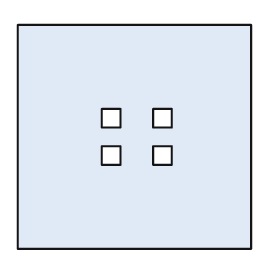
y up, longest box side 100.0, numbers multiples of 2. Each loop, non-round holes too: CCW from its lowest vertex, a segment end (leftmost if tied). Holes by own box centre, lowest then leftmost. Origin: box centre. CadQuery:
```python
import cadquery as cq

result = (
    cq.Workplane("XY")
    .moveTo(-50.0, -48.0)
    .lineTo(50.0, -48.0)
    .lineTo(50.0, 48.0)
    .lineTo(-50.0, 48.0)
    .close()
    .moveTo(-14.0, -12.0)
    .lineTo(-6.0, -12.0)
    .lineTo(-6.0, -4.0)
    .lineTo(-14.0, -4.0)
    .close()
    .moveTo(8.0, -12.0)
    .lineTo(16.0, -12.0)
    .lineTo(16.0, -4.0)
    .lineTo(8.0, -4.0)
    .close()
    .moveTo(-14.0, 4.0)
    .lineTo(-6.0, 4.0)
    .lineTo(-6.0, 12.0)
    .lineTo(-14.0, 12.0)
    .close()
    .moveTo(8.0, 4.0)
    .lineTo(16.0, 4.0)
    .lineTo(16.0, 12.0)
    .lineTo(8.0, 12.0)
    .close()
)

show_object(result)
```